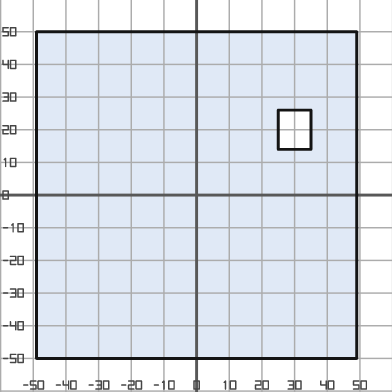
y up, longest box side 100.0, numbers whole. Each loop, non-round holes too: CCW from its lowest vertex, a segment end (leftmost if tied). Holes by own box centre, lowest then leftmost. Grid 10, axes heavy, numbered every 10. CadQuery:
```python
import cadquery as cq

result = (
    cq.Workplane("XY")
    .moveTo(-49.0, -50.0)
    .lineTo(49.0, -50.0)
    .lineTo(49.0, 50.0)
    .lineTo(-49.0, 50.0)
    .close()
    .moveTo(25.0, 14.0)
    .lineTo(35.0, 14.0)
    .lineTo(35.0, 26.0)
    .lineTo(25.0, 26.0)
    .close()
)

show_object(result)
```